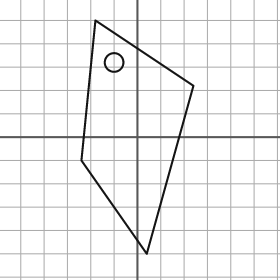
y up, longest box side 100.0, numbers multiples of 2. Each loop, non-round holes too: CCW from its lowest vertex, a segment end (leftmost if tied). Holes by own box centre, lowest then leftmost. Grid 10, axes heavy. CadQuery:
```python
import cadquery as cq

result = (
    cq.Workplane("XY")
    .moveTo(4.0, -50.0)
    .lineTo(24.0, 22.0)
    .lineTo(-18.0, 50.0)
    .lineTo(-24.0, -10.0)
    .close()
    .moveTo(-10.0, 32.0)
    .circle(4.0)
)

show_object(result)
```